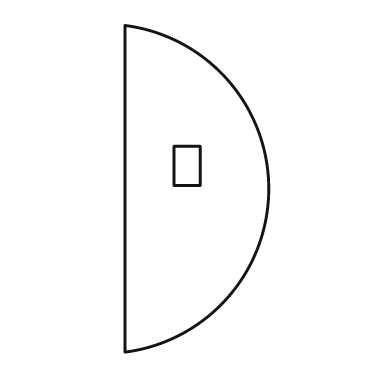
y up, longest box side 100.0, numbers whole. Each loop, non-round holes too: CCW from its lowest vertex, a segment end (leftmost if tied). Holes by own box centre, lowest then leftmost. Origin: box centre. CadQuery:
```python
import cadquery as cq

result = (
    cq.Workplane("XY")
    .moveTo(-22.0, -50.0)
    .threePointArc((22.0, 0.0), (-22.0, 50.0))
    .close()
    .moveTo(-7.0, 1.0)
    .lineTo(1.0, 1.0)
    .lineTo(1.0, 13.0)
    .lineTo(-7.0, 13.0)
    .close()
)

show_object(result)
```